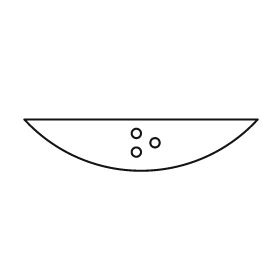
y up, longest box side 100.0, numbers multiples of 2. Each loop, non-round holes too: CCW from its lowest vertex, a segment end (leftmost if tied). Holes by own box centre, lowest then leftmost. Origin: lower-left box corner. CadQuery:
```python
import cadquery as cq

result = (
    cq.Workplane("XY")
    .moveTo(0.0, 22.0)
    .threePointArc((50.0, 0.0), (100.0, 22.0))
    .close()
    .moveTo(48.0, 8.0)
    .circle(2.0)
    .moveTo(56.0, 12.0)
    .circle(2.0)
    .moveTo(48.0, 16.0)
    .circle(2.0)
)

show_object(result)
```